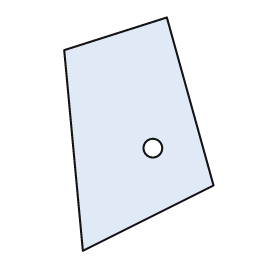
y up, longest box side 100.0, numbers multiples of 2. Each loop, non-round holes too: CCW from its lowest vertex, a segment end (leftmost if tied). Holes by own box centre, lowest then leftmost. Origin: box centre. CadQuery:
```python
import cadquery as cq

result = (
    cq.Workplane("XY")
    .moveTo(-24.0, -50.0)
    .lineTo(32.0, -22.0)
    .lineTo(12.0, 50.0)
    .lineTo(-32.0, 36.0)
    .close()
    .moveTo(6.0, -6.0)
    .circle(4.0)
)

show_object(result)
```